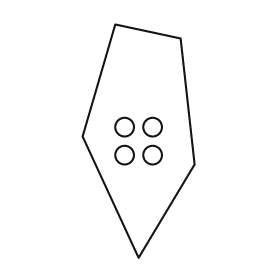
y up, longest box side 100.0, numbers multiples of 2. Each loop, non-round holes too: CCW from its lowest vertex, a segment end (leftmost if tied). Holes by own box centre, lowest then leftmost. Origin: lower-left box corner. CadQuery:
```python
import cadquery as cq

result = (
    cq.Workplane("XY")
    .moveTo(24.0, 0.0)
    .lineTo(48.0, 40.0)
    .lineTo(42.0, 94.0)
    .lineTo(14.0, 100.0)
    .lineTo(0.0, 52.0)
    .close()
    .moveTo(18.0, 44.0)
    .circle(4.0)
    .moveTo(30.0, 44.0)
    .circle(4.0)
    .moveTo(18.0, 56.0)
    .circle(4.0)
    .moveTo(30.0, 56.0)
    .circle(4.0)
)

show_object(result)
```